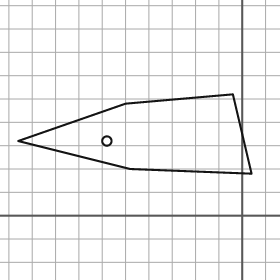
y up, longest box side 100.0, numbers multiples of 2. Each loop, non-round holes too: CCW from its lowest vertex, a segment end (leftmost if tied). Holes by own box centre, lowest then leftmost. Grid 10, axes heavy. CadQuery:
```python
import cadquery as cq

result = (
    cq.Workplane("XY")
    .moveTo(4.0, 18.0)
    .lineTo(-4.0, 52.0)
    .lineTo(-50.0, 48.0)
    .lineTo(-96.0, 32.0)
    .lineTo(-48.0, 20.0)
    .close()
    .moveTo(-58.0, 32.0)
    .circle(2.0)
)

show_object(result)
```